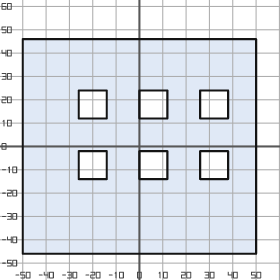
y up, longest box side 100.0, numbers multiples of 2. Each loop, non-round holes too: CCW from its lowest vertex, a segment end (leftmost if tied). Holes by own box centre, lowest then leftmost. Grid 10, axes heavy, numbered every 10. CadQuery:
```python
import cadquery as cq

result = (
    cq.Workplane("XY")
    .moveTo(-50.0, -46.0)
    .lineTo(50.0, -46.0)
    .lineTo(50.0, 46.0)
    .lineTo(-50.0, 46.0)
    .close()
    .moveTo(-26.0, -14.0)
    .lineTo(-14.0, -14.0)
    .lineTo(-14.0, -2.0)
    .lineTo(-26.0, -2.0)
    .close()
    .moveTo(0.0, -14.0)
    .lineTo(12.0, -14.0)
    .lineTo(12.0, -2.0)
    .lineTo(0.0, -2.0)
    .close()
    .moveTo(26.0, -14.0)
    .lineTo(38.0, -14.0)
    .lineTo(38.0, -2.0)
    .lineTo(26.0, -2.0)
    .close()
    .moveTo(-26.0, 12.0)
    .lineTo(-14.0, 12.0)
    .lineTo(-14.0, 24.0)
    .lineTo(-26.0, 24.0)
    .close()
    .moveTo(0.0, 12.0)
    .lineTo(12.0, 12.0)
    .lineTo(12.0, 24.0)
    .lineTo(0.0, 24.0)
    .close()
    .moveTo(26.0, 12.0)
    .lineTo(38.0, 12.0)
    .lineTo(38.0, 24.0)
    .lineTo(26.0, 24.0)
    .close()
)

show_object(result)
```